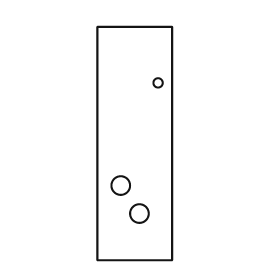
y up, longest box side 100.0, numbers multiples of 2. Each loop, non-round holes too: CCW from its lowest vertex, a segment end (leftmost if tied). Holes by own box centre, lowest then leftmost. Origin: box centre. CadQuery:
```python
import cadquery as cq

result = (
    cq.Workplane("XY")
    .moveTo(-16.0, -50.0)
    .lineTo(16.0, -50.0)
    .lineTo(16.0, 50.0)
    .lineTo(-16.0, 50.0)
    .close()
    .moveTo(2.0, -30.0)
    .circle(4.0)
    .moveTo(-6.0, -18.0)
    .circle(4.0)
    .moveTo(10.0, 26.0)
    .circle(2.0)
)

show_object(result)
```